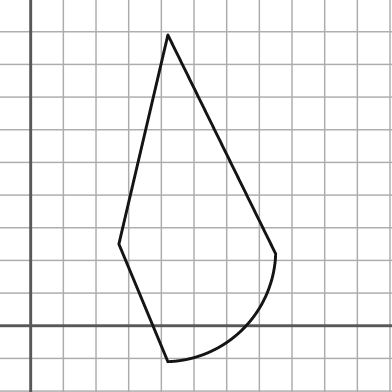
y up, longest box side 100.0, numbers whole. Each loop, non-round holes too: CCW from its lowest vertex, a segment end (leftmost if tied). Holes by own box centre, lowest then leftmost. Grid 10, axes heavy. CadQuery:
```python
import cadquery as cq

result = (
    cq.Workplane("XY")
    .moveTo(42.0, -11.0)
    .threePointArc((65.0, -1.0), (75.0, 22.0))
    .lineTo(42.0, 89.0)
    .lineTo(27.0, 25.0)
    .close()
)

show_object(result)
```